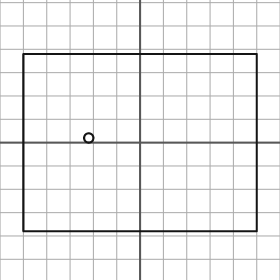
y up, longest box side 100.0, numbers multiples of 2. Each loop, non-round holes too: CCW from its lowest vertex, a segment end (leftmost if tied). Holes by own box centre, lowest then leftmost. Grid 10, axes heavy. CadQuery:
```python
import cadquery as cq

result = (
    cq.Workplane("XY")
    .moveTo(-50.0, -38.0)
    .lineTo(50.0, -38.0)
    .lineTo(50.0, 38.0)
    .lineTo(-50.0, 38.0)
    .close()
    .moveTo(-22.0, 2.0)
    .circle(2.0)
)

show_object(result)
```